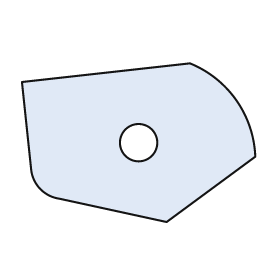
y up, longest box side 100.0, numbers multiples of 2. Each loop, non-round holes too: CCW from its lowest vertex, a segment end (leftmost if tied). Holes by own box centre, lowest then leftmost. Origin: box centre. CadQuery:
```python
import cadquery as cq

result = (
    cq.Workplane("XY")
    .moveTo(12.0, -34.0)
    .lineTo(50.0, -6.0)
    .threePointArc((42.0, 18.0), (22.0, 34.0))
    .lineTo(-50.0, 26.0)
    .lineTo(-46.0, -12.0)
    .threePointArc((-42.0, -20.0), (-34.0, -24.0))
    .close()
    .moveTo(0.0, 0.0)
    .circle(8.0)
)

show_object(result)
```